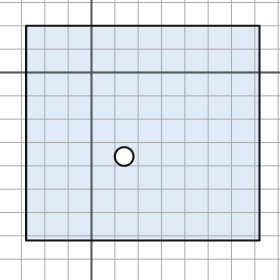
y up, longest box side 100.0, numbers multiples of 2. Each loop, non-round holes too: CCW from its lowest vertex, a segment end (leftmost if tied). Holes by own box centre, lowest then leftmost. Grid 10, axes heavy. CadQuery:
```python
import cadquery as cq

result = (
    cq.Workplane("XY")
    .moveTo(-28.0, -72.0)
    .lineTo(72.0, -72.0)
    .lineTo(72.0, 20.0)
    .lineTo(-28.0, 20.0)
    .close()
    .moveTo(14.0, -36.0)
    .circle(4.0)
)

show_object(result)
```